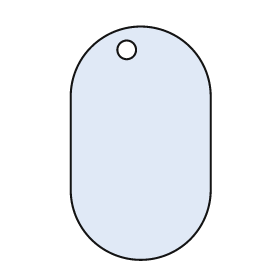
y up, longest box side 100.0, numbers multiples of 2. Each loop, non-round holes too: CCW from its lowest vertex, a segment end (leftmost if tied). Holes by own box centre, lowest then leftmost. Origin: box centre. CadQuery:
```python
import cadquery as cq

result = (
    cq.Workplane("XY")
    .moveTo(-30.0, -20.0)
    .threePointArc((0.0, -50.0), (30.0, -20.0))
    .lineTo(30.0, 20.0)
    .threePointArc((0.0, 50.0), (-30.0, 20.0))
    .close()
    .moveTo(-6.0, 40.0)
    .circle(4.0)
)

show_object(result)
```